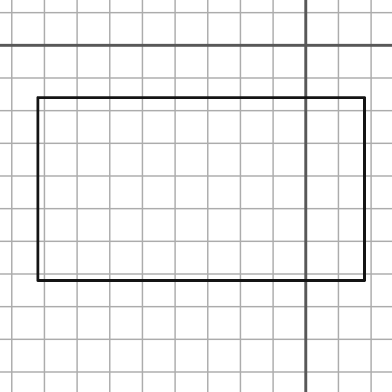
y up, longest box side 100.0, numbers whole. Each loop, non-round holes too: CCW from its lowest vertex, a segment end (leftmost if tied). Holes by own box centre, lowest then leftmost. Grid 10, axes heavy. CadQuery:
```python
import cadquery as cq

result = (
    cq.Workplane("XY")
    .moveTo(-82.0, -72.0)
    .lineTo(18.0, -72.0)
    .lineTo(18.0, -16.0)
    .lineTo(-82.0, -16.0)
    .close()
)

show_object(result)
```